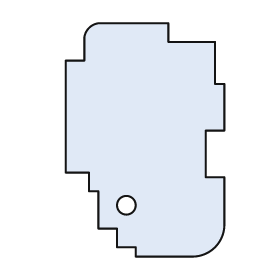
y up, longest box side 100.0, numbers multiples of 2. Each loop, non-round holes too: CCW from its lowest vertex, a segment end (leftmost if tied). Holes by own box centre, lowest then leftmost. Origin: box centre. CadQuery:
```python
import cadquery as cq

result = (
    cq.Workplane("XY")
    .moveTo(-4.0, -50.0)
    .lineTo(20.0, -50.0)
    .threePointArc((30.0, -46.0), (34.0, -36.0))
    .lineTo(34.0, -16.0)
    .lineTo(26.0, -16.0)
    .lineTo(26.0, 4.0)
    .lineTo(34.0, 4.0)
    .lineTo(34.0, 24.0)
    .lineTo(30.0, 24.0)
    .lineTo(30.0, 42.0)
    .lineTo(10.0, 42.0)
    .lineTo(10.0, 50.0)
    .lineTo(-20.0, 50.0)
    .threePointArc((-24.0, 48.0), (-26.0, 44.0))
    .lineTo(-26.0, 34.0)
    .lineTo(-34.0, 34.0)
    .lineTo(-34.0, -14.0)
    .lineTo(-24.0, -14.0)
    .lineTo(-24.0, -22.0)
    .lineTo(-20.0, -22.0)
    .lineTo(-20.0, -38.0)
    .lineTo(-12.0, -38.0)
    .lineTo(-12.0, -46.0)
    .lineTo(-4.0, -46.0)
    .close()
    .moveTo(-8.0, -28.0)
    .circle(4.0)
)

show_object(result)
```